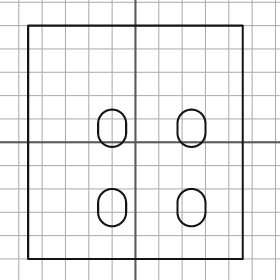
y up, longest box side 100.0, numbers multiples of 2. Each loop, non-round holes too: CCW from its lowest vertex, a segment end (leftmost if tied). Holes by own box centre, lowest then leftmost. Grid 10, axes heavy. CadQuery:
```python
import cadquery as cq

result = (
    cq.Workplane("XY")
    .moveTo(-46.0, -50.0)
    .lineTo(46.0, -50.0)
    .lineTo(46.0, 50.0)
    .lineTo(-46.0, 50.0)
    .close()
    .moveTo(-16.0, -30.0)
    .threePointArc((-10.0, -36.0), (-4.0, -30.0))
    .lineTo(-4.0, -26.0)
    .threePointArc((-10.0, -20.0), (-16.0, -26.0))
    .close()
    .moveTo(18.0, -30.0)
    .threePointArc((24.0, -36.0), (30.0, -30.0))
    .lineTo(30.0, -26.0)
    .threePointArc((24.0, -20.0), (18.0, -26.0))
    .close()
    .moveTo(-16.0, 4.0)
    .threePointArc((-10.0, -2.0), (-4.0, 4.0))
    .lineTo(-4.0, 8.0)
    .threePointArc((-10.0, 14.0), (-16.0, 8.0))
    .close()
    .moveTo(18.0, 4.0)
    .threePointArc((24.0, -2.0), (30.0, 4.0))
    .lineTo(30.0, 8.0)
    .threePointArc((24.0, 14.0), (18.0, 8.0))
    .close()
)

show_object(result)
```